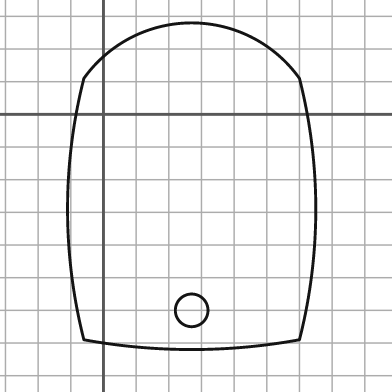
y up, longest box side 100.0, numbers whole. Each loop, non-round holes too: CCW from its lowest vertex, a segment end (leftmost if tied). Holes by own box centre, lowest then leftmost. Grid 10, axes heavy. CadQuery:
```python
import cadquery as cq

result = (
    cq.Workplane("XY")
    .moveTo(-6.0, -69.0)
    .threePointArc((27.0, -72.0), (60.0, -69.0))
    .threePointArc((65.0, -29.0), (60.0, 11.0))
    .threePointArc((27.0, 28.0), (-6.0, 11.0))
    .threePointArc((-11.0, -29.0), (-6.0, -69.0))
    .close()
    .moveTo(27.0, -60.0)
    .circle(5.0)
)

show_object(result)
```